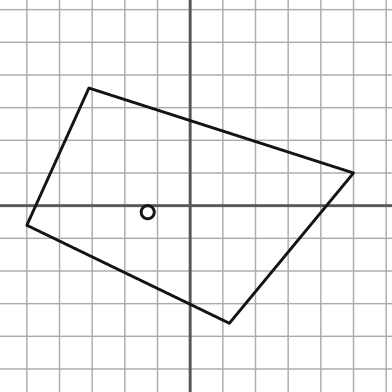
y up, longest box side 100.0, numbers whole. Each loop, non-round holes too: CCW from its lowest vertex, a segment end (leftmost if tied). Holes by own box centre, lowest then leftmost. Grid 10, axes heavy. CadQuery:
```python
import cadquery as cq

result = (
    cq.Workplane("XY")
    .moveTo(12.0, -36.0)
    .lineTo(50.0, 10.0)
    .lineTo(-31.0, 36.0)
    .lineTo(-50.0, -6.0)
    .close()
    .moveTo(-13.0, -2.0)
    .circle(2.0)
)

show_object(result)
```